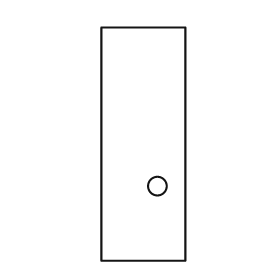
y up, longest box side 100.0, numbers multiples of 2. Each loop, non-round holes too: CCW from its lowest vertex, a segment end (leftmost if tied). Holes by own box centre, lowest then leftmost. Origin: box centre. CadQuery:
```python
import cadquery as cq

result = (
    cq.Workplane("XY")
    .moveTo(-18.0, -50.0)
    .lineTo(18.0, -50.0)
    .lineTo(18.0, 50.0)
    .lineTo(-18.0, 50.0)
    .close()
    .moveTo(6.0, -18.0)
    .circle(4.0)
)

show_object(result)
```